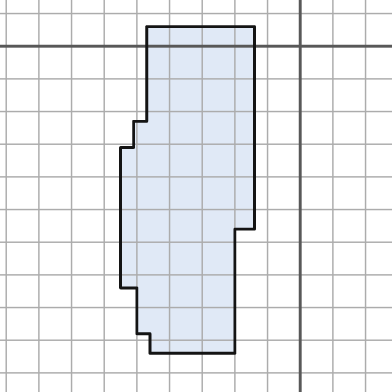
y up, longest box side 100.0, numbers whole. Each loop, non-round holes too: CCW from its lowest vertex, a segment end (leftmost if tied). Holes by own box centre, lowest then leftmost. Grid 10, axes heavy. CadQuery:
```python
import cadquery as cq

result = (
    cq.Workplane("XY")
    .moveTo(-46.0, -94.0)
    .lineTo(-20.0, -94.0)
    .lineTo(-20.0, -56.0)
    .lineTo(-14.0, -56.0)
    .lineTo(-14.0, 6.0)
    .lineTo(-47.0, 6.0)
    .lineTo(-47.0, -23.0)
    .lineTo(-51.0, -23.0)
    .lineTo(-51.0, -31.0)
    .lineTo(-55.0, -31.0)
    .lineTo(-55.0, -74.0)
    .lineTo(-50.0, -74.0)
    .lineTo(-50.0, -88.0)
    .lineTo(-46.0, -88.0)
    .close()
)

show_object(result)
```